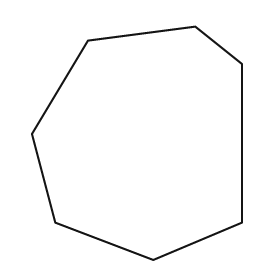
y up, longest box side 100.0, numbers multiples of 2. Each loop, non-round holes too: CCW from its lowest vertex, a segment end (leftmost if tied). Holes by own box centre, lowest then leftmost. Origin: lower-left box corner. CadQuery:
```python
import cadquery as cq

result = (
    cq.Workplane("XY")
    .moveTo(52.0, 0.0)
    .lineTo(90.0, 16.0)
    .lineTo(90.0, 84.0)
    .lineTo(70.0, 100.0)
    .lineTo(24.0, 94.0)
    .lineTo(0.0, 54.0)
    .lineTo(10.0, 16.0)
    .close()
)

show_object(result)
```